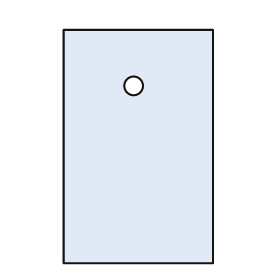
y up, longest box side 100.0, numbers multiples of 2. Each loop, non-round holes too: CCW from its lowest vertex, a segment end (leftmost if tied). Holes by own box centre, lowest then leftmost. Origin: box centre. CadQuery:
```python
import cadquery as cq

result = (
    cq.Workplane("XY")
    .moveTo(-32.0, -50.0)
    .lineTo(32.0, -50.0)
    .lineTo(32.0, 50.0)
    .lineTo(-32.0, 50.0)
    .close()
    .moveTo(-2.0, 26.0)
    .circle(4.0)
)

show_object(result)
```